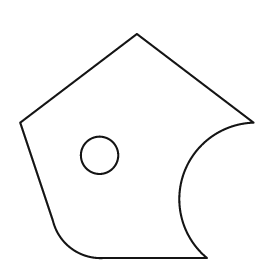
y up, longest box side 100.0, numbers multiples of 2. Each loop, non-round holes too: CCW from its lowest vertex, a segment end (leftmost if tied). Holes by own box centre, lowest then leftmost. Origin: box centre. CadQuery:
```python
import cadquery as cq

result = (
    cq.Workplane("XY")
    .moveTo(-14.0, -48.0)
    .lineTo(30.0, -48.0)
    .threePointArc((20.0, -12.0), (50.0, 10.0))
    .lineTo(0.0, 48.0)
    .lineTo(-50.0, 10.0)
    .lineTo(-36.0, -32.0)
    .threePointArc((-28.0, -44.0), (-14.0, -48.0))
    .close()
    .moveTo(-16.0, -4.0)
    .circle(8.0)
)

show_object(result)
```